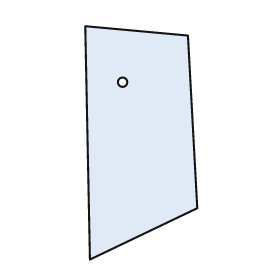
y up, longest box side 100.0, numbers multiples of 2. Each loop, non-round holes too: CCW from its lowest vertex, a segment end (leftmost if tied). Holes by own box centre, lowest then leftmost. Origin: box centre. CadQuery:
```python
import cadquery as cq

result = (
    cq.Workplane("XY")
    .moveTo(-22.0, -50.0)
    .lineTo(24.0, -28.0)
    .lineTo(20.0, 46.0)
    .lineTo(-24.0, 50.0)
    .close()
    .moveTo(-8.0, 26.0)
    .circle(2.0)
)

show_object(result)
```